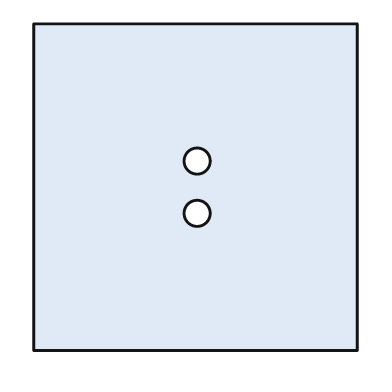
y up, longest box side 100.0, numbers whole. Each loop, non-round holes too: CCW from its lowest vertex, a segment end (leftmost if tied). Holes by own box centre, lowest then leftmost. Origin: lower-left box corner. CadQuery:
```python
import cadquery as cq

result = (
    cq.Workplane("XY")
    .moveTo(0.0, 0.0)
    .lineTo(99.0, 0.0)
    .lineTo(99.0, 100.0)
    .lineTo(0.0, 100.0)
    .close()
    .moveTo(50.0, 42.0)
    .circle(4.0)
    .moveTo(50.0, 58.0)
    .circle(4.0)
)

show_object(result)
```